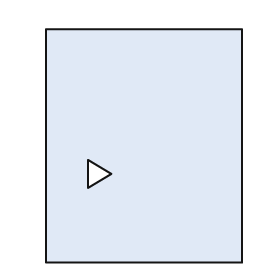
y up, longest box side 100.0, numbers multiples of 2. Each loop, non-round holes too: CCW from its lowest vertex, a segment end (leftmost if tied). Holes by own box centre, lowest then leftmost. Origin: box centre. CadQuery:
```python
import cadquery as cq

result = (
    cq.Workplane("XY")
    .moveTo(-42.0, -50.0)
    .lineTo(42.0, -50.0)
    .lineTo(42.0, 50.0)
    .lineTo(-42.0, 50.0)
    .close()
    .moveTo(-24.0, -18.0)
    .lineTo(-14.0, -12.0)
    .lineTo(-24.0, -6.0)
    .close()
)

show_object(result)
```